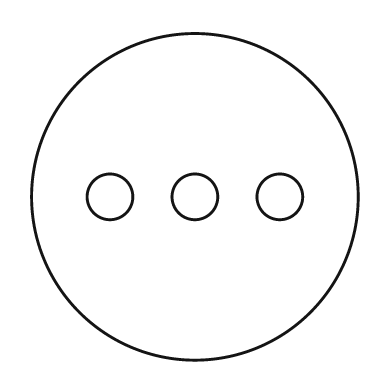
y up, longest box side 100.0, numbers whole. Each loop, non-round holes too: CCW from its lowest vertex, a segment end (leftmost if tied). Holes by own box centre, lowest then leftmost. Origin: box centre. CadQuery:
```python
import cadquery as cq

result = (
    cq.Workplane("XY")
    .moveTo(0.0, 0.0)
    .circle(50.0)
    .moveTo(-26.0, 0.0)
    .circle(7.0)
    .moveTo(0.0, 0.0)
    .circle(7.0)
    .moveTo(26.0, 0.0)
    .circle(7.0)
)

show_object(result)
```